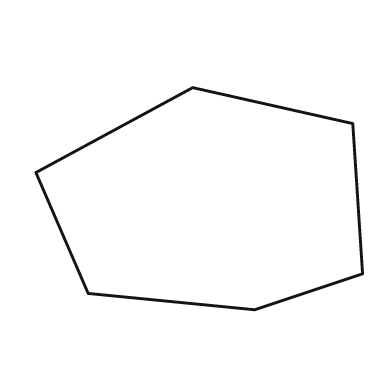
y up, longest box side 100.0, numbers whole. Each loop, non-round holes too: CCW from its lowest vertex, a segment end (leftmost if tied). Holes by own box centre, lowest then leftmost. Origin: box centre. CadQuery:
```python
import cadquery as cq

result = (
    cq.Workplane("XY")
    .moveTo(17.0, -34.0)
    .lineTo(50.0, -23.0)
    .lineTo(47.0, 23.0)
    .lineTo(-2.0, 34.0)
    .lineTo(-50.0, 8.0)
    .lineTo(-34.0, -29.0)
    .close()
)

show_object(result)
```